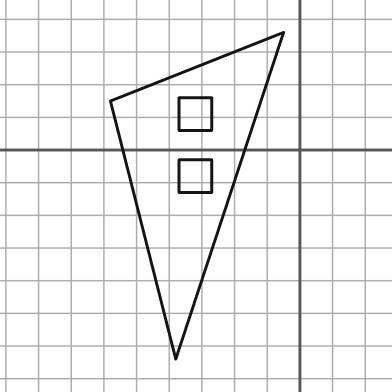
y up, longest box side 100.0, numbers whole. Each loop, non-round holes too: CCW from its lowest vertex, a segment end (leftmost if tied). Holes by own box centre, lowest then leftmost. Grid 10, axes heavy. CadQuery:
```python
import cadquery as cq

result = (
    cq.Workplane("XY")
    .moveTo(-38.0, -64.0)
    .lineTo(-5.0, 36.0)
    .lineTo(-58.0, 15.0)
    .close()
    .moveTo(-37.0, -13.0)
    .lineTo(-27.0, -13.0)
    .lineTo(-27.0, -3.0)
    .lineTo(-37.0, -3.0)
    .close()
    .moveTo(-37.0, 6.0)
    .lineTo(-27.0, 6.0)
    .lineTo(-27.0, 16.0)
    .lineTo(-37.0, 16.0)
    .close()
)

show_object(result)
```